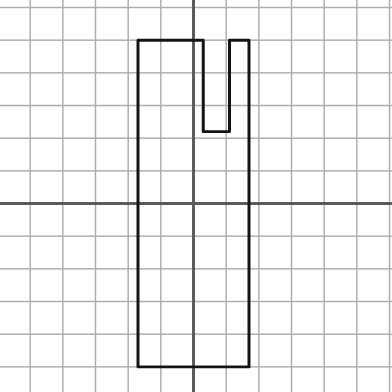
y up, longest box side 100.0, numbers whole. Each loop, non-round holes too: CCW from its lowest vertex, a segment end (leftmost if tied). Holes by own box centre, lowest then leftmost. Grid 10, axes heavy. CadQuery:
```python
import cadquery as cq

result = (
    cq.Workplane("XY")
    .moveTo(-17.0, -50.0)
    .lineTo(17.0, -50.0)
    .lineTo(17.0, 50.0)
    .lineTo(11.0, 50.0)
    .lineTo(11.0, 22.0)
    .lineTo(3.0, 22.0)
    .lineTo(3.0, 50.0)
    .lineTo(-17.0, 50.0)
    .close()
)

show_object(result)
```